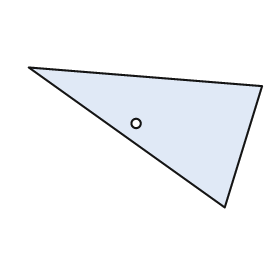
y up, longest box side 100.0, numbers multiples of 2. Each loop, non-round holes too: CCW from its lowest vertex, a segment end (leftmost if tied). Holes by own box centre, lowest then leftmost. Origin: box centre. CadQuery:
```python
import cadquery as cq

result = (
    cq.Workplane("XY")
    .moveTo(34.0, -30.0)
    .lineTo(50.0, 22.0)
    .lineTo(-50.0, 30.0)
    .close()
    .moveTo(-4.0, 6.0)
    .circle(2.0)
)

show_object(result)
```